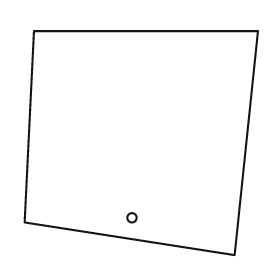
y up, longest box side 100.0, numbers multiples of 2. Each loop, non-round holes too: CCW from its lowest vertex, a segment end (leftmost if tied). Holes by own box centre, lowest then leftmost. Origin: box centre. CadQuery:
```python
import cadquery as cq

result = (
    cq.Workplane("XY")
    .moveTo(40.0, -48.0)
    .lineTo(50.0, 48.0)
    .lineTo(-46.0, 48.0)
    .lineTo(-50.0, -34.0)
    .close()
    .moveTo(-4.0, -32.0)
    .circle(2.0)
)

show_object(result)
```